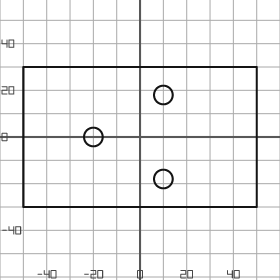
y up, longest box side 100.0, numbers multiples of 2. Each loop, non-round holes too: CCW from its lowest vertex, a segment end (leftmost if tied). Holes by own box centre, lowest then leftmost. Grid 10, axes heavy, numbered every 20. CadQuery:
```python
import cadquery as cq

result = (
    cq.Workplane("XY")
    .moveTo(-50.0, -30.0)
    .lineTo(50.0, -30.0)
    .lineTo(50.0, 30.0)
    .lineTo(-50.0, 30.0)
    .close()
    .moveTo(10.0, -18.0)
    .circle(4.0)
    .moveTo(-20.0, 0.0)
    .circle(4.0)
    .moveTo(10.0, 18.0)
    .circle(4.0)
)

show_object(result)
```